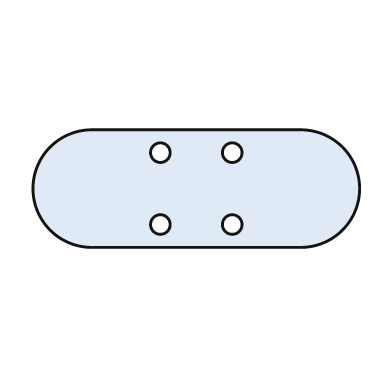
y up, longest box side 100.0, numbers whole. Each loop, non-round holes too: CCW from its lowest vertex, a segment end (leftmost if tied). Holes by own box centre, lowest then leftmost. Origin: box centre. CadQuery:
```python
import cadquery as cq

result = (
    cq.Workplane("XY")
    .moveTo(-32.0, -18.0)
    .lineTo(32.0, -18.0)
    .threePointArc((50.0, 0.0), (32.0, 18.0))
    .lineTo(-32.0, 18.0)
    .threePointArc((-50.0, 0.0), (-32.0, -18.0))
    .close()
    .moveTo(-11.0, -11.0)
    .circle(3.0)
    .moveTo(11.0, -11.0)
    .circle(3.0)
    .moveTo(-11.0, 11.0)
    .circle(3.0)
    .moveTo(11.0, 11.0)
    .circle(3.0)
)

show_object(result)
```